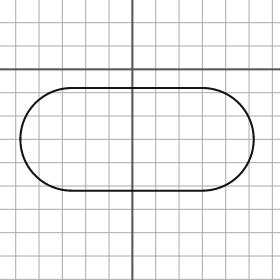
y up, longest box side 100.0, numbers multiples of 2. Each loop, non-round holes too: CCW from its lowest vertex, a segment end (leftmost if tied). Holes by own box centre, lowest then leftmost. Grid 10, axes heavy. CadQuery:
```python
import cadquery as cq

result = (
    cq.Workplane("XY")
    .moveTo(-26.0, -52.0)
    .lineTo(30.0, -52.0)
    .threePointArc((52.0, -30.0), (30.0, -8.0))
    .lineTo(-26.0, -8.0)
    .threePointArc((-48.0, -30.0), (-26.0, -52.0))
    .close()
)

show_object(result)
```